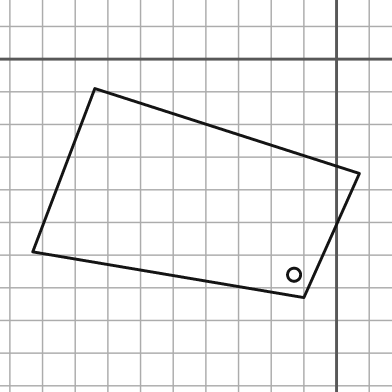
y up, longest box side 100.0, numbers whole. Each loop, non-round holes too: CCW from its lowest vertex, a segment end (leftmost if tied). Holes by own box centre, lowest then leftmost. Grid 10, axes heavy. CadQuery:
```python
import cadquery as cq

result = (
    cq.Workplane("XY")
    .moveTo(-10.0, -73.0)
    .lineTo(7.0, -35.0)
    .lineTo(-74.0, -9.0)
    .lineTo(-93.0, -59.0)
    .close()
    .moveTo(-13.0, -66.0)
    .circle(2.0)
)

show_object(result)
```